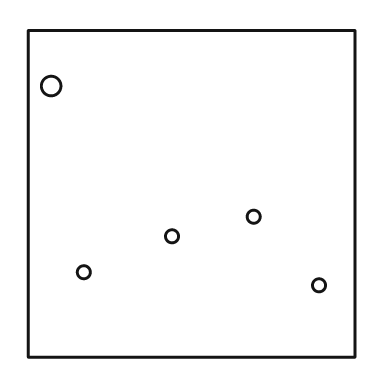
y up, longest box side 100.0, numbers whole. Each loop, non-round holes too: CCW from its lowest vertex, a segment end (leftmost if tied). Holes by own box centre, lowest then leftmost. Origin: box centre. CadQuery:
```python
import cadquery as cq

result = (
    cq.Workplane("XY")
    .moveTo(-50.0, -50.0)
    .lineTo(50.0, -50.0)
    .lineTo(50.0, 50.0)
    .lineTo(-50.0, 50.0)
    .close()
    .moveTo(39.0, -28.0)
    .circle(2.0)
    .moveTo(-33.0, -24.0)
    .circle(2.0)
    .moveTo(-6.0, -13.0)
    .circle(2.0)
    .moveTo(19.0, -7.0)
    .circle(2.0)
    .moveTo(-43.0, 33.0)
    .circle(3.0)
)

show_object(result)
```